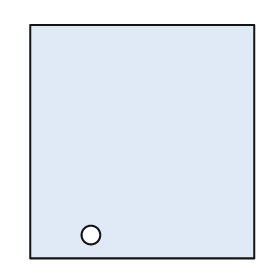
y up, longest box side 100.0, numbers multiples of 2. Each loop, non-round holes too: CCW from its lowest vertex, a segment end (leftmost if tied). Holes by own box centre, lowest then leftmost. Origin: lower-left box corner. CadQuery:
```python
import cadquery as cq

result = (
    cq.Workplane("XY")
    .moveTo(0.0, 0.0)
    .lineTo(96.0, 0.0)
    .lineTo(96.0, 100.0)
    .lineTo(0.0, 100.0)
    .close()
    .moveTo(26.0, 10.0)
    .circle(4.0)
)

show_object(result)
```